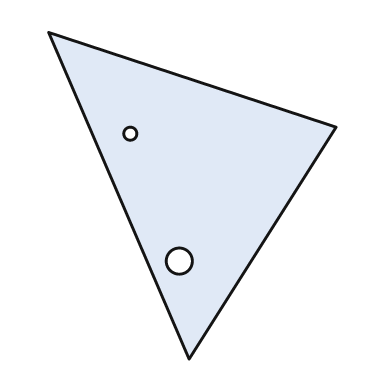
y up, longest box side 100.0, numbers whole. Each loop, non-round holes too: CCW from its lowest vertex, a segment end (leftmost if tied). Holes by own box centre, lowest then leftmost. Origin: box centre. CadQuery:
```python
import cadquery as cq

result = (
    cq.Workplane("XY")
    .moveTo(-1.0, -50.0)
    .lineTo(44.0, 21.0)
    .lineTo(-44.0, 50.0)
    .close()
    .moveTo(-4.0, -20.0)
    .circle(4.0)
    .moveTo(-19.0, 19.0)
    .circle(2.0)
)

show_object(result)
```